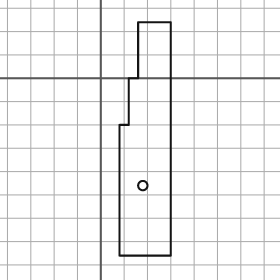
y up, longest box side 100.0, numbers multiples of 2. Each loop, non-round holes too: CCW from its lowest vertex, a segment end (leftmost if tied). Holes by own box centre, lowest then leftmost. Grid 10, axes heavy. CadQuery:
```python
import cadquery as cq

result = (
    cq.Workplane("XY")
    .moveTo(8.0, -76.0)
    .lineTo(30.0, -76.0)
    .lineTo(30.0, 24.0)
    .lineTo(16.0, 24.0)
    .lineTo(16.0, 0.0)
    .lineTo(12.0, 0.0)
    .lineTo(12.0, -20.0)
    .lineTo(8.0, -20.0)
    .close()
    .moveTo(18.0, -46.0)
    .circle(2.0)
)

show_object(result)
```